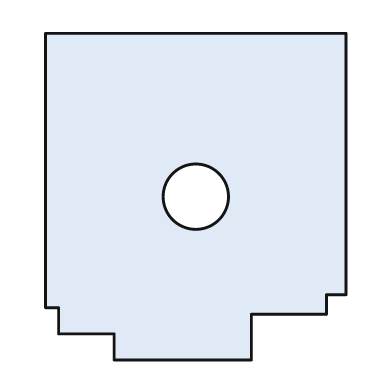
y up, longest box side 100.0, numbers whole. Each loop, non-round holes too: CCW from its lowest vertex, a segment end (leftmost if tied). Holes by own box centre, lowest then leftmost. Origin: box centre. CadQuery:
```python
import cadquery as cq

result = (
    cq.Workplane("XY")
    .moveTo(-25.0, -50.0)
    .lineTo(17.0, -50.0)
    .lineTo(17.0, -36.0)
    .lineTo(40.0, -36.0)
    .lineTo(40.0, -30.0)
    .lineTo(46.0, -30.0)
    .lineTo(46.0, 50.0)
    .lineTo(-46.0, 50.0)
    .lineTo(-46.0, -34.0)
    .lineTo(-42.0, -34.0)
    .lineTo(-42.0, -42.0)
    .lineTo(-25.0, -42.0)
    .close()
    .moveTo(0.0, 0.0)
    .circle(10.0)
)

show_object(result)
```